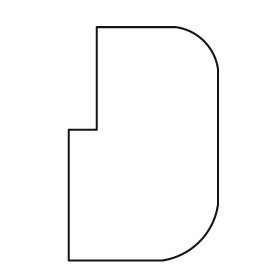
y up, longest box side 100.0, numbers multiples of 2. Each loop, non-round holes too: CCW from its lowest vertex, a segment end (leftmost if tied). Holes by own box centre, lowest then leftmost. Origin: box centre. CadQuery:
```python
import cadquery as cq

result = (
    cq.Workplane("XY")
    .moveTo(-32.0, -50.0)
    .lineTo(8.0, -50.0)
    .threePointArc((24.0, -42.0), (32.0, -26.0))
    .lineTo(32.0, 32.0)
    .threePointArc((26.0, 44.0), (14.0, 50.0))
    .lineTo(-20.0, 50.0)
    .lineTo(-20.0, 6.0)
    .lineTo(-32.0, 6.0)
    .close()
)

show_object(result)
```